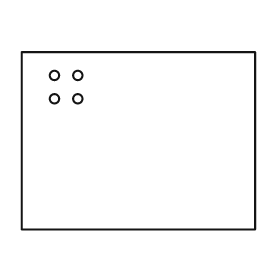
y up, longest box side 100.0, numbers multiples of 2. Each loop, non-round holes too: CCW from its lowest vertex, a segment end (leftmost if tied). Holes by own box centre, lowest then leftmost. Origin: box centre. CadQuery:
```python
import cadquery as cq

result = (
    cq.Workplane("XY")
    .moveTo(-50.0, -38.0)
    .lineTo(50.0, -38.0)
    .lineTo(50.0, 38.0)
    .lineTo(-50.0, 38.0)
    .close()
    .moveTo(-36.0, 18.0)
    .circle(2.0)
    .moveTo(-26.0, 18.0)
    .circle(2.0)
    .moveTo(-36.0, 28.0)
    .circle(2.0)
    .moveTo(-26.0, 28.0)
    .circle(2.0)
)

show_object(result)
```